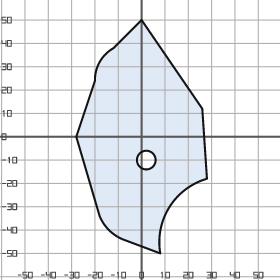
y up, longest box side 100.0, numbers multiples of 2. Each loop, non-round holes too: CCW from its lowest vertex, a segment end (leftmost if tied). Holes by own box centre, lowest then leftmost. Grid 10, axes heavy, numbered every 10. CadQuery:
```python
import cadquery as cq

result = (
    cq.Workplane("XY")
    .moveTo(8.0, -50.0)
    .threePointArc((12.0, -30.0), (28.0, -18.0))
    .lineTo(26.0, 12.0)
    .lineTo(0.0, 50.0)
    .lineTo(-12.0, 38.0)
    .threePointArc((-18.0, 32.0), (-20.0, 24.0))
    .lineTo(-28.0, 0.0)
    .lineTo(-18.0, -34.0)
    .threePointArc((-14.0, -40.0), (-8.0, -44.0))
    .close()
    .moveTo(2.0, -10.0)
    .circle(4.0)
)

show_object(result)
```